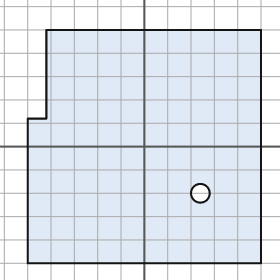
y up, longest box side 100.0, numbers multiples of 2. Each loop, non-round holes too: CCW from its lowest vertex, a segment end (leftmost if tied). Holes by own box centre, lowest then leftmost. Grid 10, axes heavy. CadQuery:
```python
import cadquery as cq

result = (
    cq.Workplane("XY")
    .moveTo(-50.0, -50.0)
    .lineTo(50.0, -50.0)
    .lineTo(50.0, 50.0)
    .lineTo(-42.0, 50.0)
    .lineTo(-42.0, 12.0)
    .lineTo(-50.0, 12.0)
    .close()
    .moveTo(24.0, -20.0)
    .circle(4.0)
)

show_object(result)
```